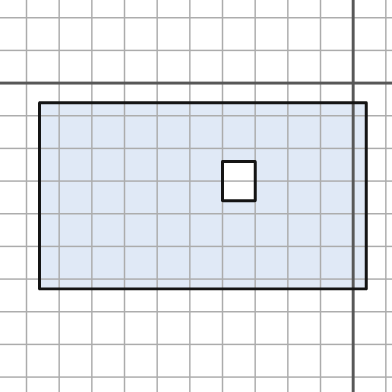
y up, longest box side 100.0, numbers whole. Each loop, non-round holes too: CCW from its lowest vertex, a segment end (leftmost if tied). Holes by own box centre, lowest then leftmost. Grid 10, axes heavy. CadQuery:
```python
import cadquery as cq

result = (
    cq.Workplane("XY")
    .moveTo(-96.0, -63.0)
    .lineTo(4.0, -63.0)
    .lineTo(4.0, -6.0)
    .lineTo(-96.0, -6.0)
    .close()
    .moveTo(-40.0, -36.0)
    .lineTo(-30.0, -36.0)
    .lineTo(-30.0, -24.0)
    .lineTo(-40.0, -24.0)
    .close()
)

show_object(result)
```